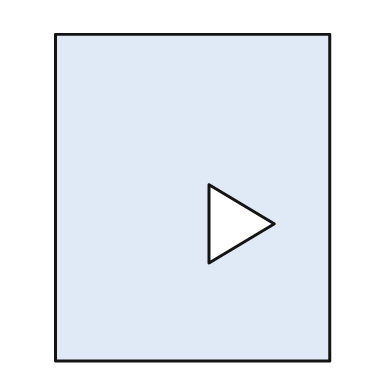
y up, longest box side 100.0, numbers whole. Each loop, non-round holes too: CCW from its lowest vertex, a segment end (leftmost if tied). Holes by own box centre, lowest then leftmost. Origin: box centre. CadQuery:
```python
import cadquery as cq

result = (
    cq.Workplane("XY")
    .moveTo(-42.0, -50.0)
    .lineTo(42.0, -50.0)
    .lineTo(42.0, 50.0)
    .lineTo(-42.0, 50.0)
    .close()
    .moveTo(5.0, -20.0)
    .lineTo(25.0, -8.0)
    .lineTo(5.0, 4.0)
    .close()
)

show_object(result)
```